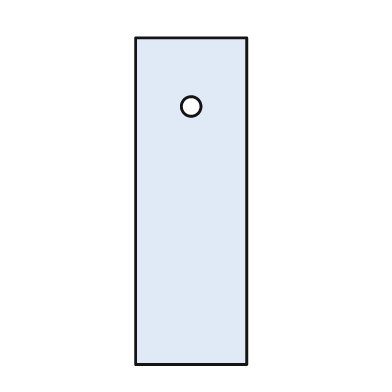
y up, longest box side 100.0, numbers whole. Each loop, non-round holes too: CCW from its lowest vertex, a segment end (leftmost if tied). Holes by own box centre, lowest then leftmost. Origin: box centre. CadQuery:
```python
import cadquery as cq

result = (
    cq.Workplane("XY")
    .moveTo(-17.0, -50.0)
    .lineTo(17.0, -50.0)
    .lineTo(17.0, 50.0)
    .lineTo(-17.0, 50.0)
    .close()
    .moveTo(0.0, 29.0)
    .circle(3.0)
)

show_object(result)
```